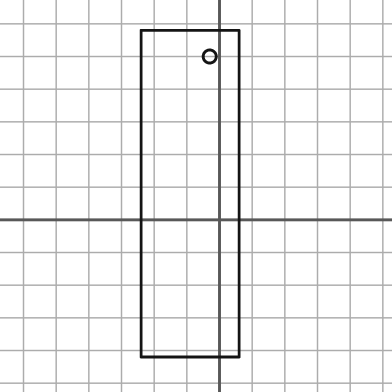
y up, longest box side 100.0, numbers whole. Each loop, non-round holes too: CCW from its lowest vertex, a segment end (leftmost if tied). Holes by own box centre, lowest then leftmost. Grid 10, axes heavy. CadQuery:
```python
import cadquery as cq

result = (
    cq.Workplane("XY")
    .moveTo(-24.0, -42.0)
    .lineTo(6.0, -42.0)
    .lineTo(6.0, 58.0)
    .lineTo(-24.0, 58.0)
    .close()
    .moveTo(-3.0, 50.0)
    .circle(2.0)
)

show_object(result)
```